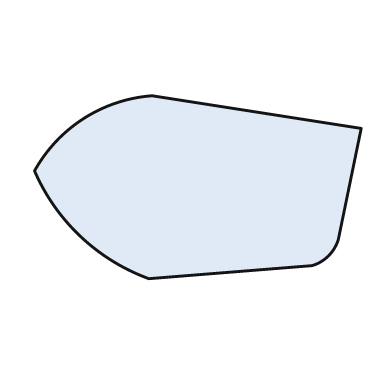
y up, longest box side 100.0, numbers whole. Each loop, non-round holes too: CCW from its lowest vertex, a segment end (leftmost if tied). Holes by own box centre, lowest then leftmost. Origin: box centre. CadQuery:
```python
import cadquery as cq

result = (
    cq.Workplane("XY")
    .moveTo(-15.0, -28.0)
    .lineTo(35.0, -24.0)
    .threePointArc((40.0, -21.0), (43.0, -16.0))
    .lineTo(50.0, 18.0)
    .lineTo(-14.0, 28.0)
    .threePointArc((-35.0, 21.0), (-50.0, 5.0))
    .threePointArc((-36.0, -15.0), (-15.0, -28.0))
    .close()
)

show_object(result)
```